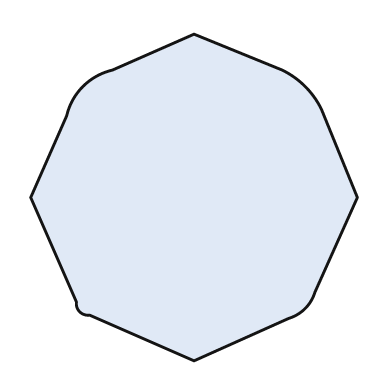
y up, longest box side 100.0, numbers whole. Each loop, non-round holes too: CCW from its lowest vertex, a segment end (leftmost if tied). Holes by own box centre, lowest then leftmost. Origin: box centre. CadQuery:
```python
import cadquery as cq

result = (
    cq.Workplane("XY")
    .moveTo(0.0, -50.0)
    .lineTo(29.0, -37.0)
    .threePointArc((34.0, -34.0), (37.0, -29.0))
    .lineTo(50.0, 0.0)
    .lineTo(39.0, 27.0)
    .threePointArc((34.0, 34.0), (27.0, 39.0))
    .lineTo(0.0, 50.0)
    .lineTo(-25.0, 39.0)
    .threePointArc((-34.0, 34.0), (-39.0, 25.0))
    .lineTo(-50.0, 0.0)
    .lineTo(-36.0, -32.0)
    .threePointArc((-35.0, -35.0), (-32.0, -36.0))
    .close()
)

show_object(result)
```